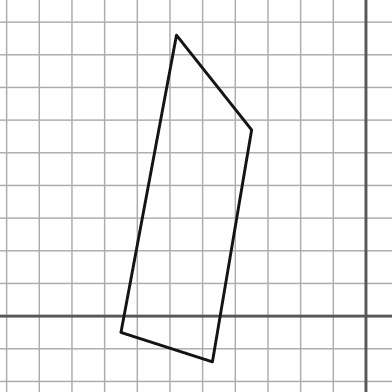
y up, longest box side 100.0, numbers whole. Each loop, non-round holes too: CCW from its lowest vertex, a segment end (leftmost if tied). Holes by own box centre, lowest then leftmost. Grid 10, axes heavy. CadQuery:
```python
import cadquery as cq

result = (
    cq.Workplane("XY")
    .moveTo(-47.0, -14.0)
    .lineTo(-35.0, 57.0)
    .lineTo(-58.0, 86.0)
    .lineTo(-75.0, -5.0)
    .close()
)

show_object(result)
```